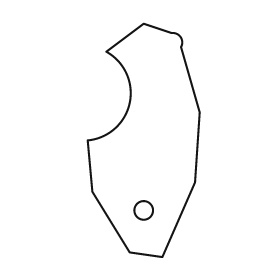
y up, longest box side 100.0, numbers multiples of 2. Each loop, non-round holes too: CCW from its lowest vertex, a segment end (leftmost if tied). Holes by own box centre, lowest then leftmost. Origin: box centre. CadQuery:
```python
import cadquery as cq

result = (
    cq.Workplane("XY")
    .moveTo(8.0, -50.0)
    .lineTo(22.0, -18.0)
    .lineTo(24.0, 12.0)
    .lineTo(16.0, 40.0)
    .threePointArc((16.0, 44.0), (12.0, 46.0))
    .lineTo(0.0, 50.0)
    .lineTo(-16.0, 38.0)
    .threePointArc((-6.0, 16.0), (-24.0, 0.0))
    .lineTo(-22.0, -22.0)
    .lineTo(-6.0, -48.0)
    .close()
    .moveTo(0.0, -30.0)
    .circle(4.0)
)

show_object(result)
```